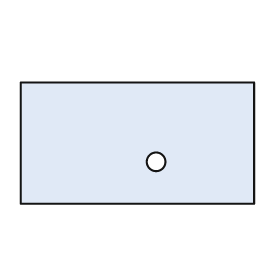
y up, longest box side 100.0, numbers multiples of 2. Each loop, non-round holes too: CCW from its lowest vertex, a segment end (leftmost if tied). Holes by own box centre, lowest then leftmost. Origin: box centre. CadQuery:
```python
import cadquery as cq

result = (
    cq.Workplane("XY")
    .moveTo(-50.0, -26.0)
    .lineTo(50.0, -26.0)
    .lineTo(50.0, 26.0)
    .lineTo(-50.0, 26.0)
    .close()
    .moveTo(8.0, -8.0)
    .circle(4.0)
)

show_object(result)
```